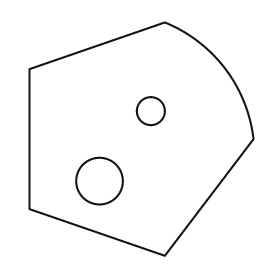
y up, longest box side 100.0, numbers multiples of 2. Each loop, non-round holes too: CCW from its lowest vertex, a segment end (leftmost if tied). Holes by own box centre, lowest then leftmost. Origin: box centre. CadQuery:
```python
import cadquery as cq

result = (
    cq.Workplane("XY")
    .moveTo(10.0, -50.0)
    .lineTo(48.0, 0.0)
    .threePointArc((36.0, 30.0), (10.0, 50.0))
    .lineTo(-48.0, 30.0)
    .lineTo(-48.0, -30.0)
    .close()
    .moveTo(-18.0, -18.0)
    .circle(10.0)
    .moveTo(4.0, 12.0)
    .circle(6.0)
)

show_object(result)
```